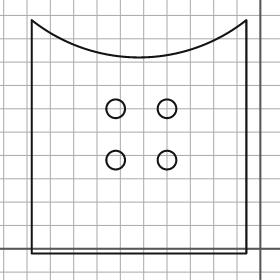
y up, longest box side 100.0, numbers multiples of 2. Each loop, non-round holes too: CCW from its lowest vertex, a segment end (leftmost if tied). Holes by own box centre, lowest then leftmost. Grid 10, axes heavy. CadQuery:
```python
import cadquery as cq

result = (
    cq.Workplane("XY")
    .moveTo(-98.0, -2.0)
    .lineTo(-6.0, -2.0)
    .lineTo(-6.0, 98.0)
    .threePointArc((-52.0, 82.0), (-98.0, 98.0))
    .close()
    .moveTo(-62.0, 38.0)
    .circle(4.0)
    .moveTo(-40.0, 38.0)
    .circle(4.0)
    .moveTo(-62.0, 60.0)
    .circle(4.0)
    .moveTo(-40.0, 60.0)
    .circle(4.0)
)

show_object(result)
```